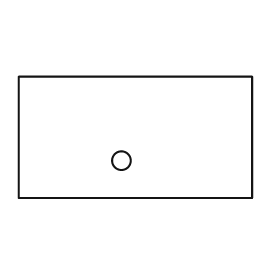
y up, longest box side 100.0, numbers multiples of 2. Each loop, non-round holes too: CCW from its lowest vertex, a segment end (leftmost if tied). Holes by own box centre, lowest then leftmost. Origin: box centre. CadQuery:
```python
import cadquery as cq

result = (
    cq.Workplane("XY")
    .moveTo(-50.0, -26.0)
    .lineTo(50.0, -26.0)
    .lineTo(50.0, 26.0)
    .lineTo(-50.0, 26.0)
    .close()
    .moveTo(-6.0, -10.0)
    .circle(4.0)
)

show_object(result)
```